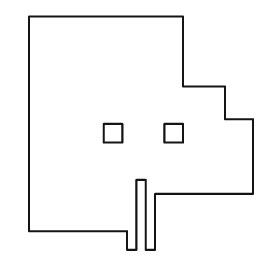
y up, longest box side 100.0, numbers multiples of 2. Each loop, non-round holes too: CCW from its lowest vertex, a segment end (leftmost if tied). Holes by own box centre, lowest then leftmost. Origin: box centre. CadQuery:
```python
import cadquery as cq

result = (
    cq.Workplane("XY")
    .moveTo(-6.0, -50.0)
    .lineTo(-2.0, -50.0)
    .lineTo(-2.0, -20.0)
    .lineTo(2.0, -20.0)
    .lineTo(2.0, -50.0)
    .lineTo(6.0, -50.0)
    .lineTo(6.0, -26.0)
    .lineTo(48.0, -26.0)
    .lineTo(48.0, 6.0)
    .lineTo(36.0, 6.0)
    .lineTo(36.0, 20.0)
    .lineTo(18.0, 20.0)
    .lineTo(18.0, 50.0)
    .lineTo(-48.0, 50.0)
    .lineTo(-48.0, -42.0)
    .lineTo(-6.0, -42.0)
    .close()
    .moveTo(-16.0, -4.0)
    .lineTo(-8.0, -4.0)
    .lineTo(-8.0, 4.0)
    .lineTo(-16.0, 4.0)
    .close()
    .moveTo(10.0, -4.0)
    .lineTo(18.0, -4.0)
    .lineTo(18.0, 4.0)
    .lineTo(10.0, 4.0)
    .close()
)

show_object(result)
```